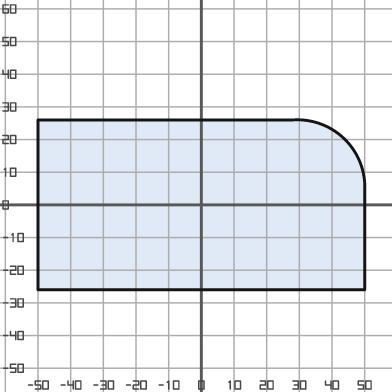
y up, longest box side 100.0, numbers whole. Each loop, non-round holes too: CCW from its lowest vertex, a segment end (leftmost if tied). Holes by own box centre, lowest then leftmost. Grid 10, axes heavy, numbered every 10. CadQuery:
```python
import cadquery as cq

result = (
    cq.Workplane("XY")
    .moveTo(-50.0, -26.0)
    .lineTo(50.0, -26.0)
    .lineTo(50.0, 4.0)
    .threePointArc((44.0, 20.0), (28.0, 26.0))
    .lineTo(-50.0, 26.0)
    .close()
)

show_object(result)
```